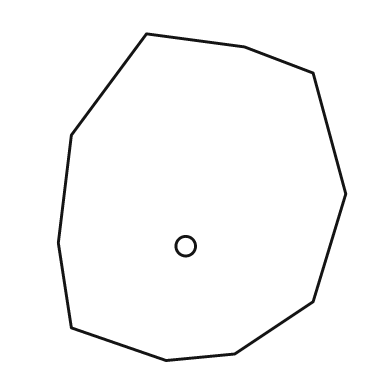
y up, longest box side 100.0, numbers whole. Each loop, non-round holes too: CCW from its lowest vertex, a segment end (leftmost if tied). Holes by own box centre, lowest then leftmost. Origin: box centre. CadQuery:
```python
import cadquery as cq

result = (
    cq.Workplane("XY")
    .moveTo(-11.0, -50.0)
    .lineTo(10.0, -48.0)
    .lineTo(34.0, -32.0)
    .lineTo(44.0, 1.0)
    .lineTo(34.0, 38.0)
    .lineTo(13.0, 46.0)
    .lineTo(-17.0, 50.0)
    .lineTo(-40.0, 19.0)
    .lineTo(-44.0, -14.0)
    .lineTo(-40.0, -40.0)
    .close()
    .moveTo(-5.0, -15.0)
    .circle(3.0)
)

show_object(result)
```